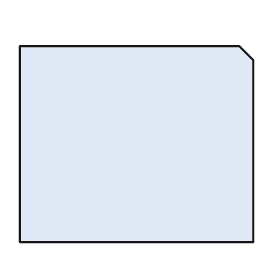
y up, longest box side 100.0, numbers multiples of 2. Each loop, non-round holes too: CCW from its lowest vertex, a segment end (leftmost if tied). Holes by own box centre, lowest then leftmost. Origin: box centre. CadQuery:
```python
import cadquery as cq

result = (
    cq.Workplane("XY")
    .moveTo(-50.0, -42.0)
    .lineTo(50.0, -42.0)
    .lineTo(50.0, 36.0)
    .lineTo(44.0, 42.0)
    .lineTo(-50.0, 42.0)
    .close()
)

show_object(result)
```